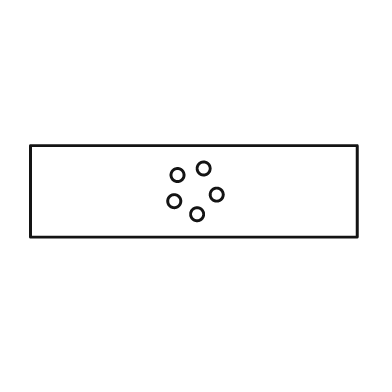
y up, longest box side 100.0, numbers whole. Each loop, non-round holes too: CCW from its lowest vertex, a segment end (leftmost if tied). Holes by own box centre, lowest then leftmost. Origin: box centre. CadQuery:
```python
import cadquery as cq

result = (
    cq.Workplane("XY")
    .moveTo(-50.0, -14.0)
    .lineTo(50.0, -14.0)
    .lineTo(50.0, 14.0)
    .lineTo(-50.0, 14.0)
    .close()
    .moveTo(1.0, -7.0)
    .circle(2.0)
    .moveTo(-6.0, -3.0)
    .circle(2.0)
    .moveTo(7.0, -1.0)
    .circle(2.0)
    .moveTo(-5.0, 5.0)
    .circle(2.0)
    .moveTo(3.0, 7.0)
    .circle(2.0)
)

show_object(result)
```